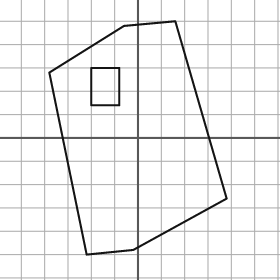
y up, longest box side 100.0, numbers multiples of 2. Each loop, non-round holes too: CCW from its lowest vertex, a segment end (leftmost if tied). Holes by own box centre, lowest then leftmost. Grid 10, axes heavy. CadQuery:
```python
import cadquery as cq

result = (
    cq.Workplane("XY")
    .moveTo(-22.0, -50.0)
    .lineTo(-2.0, -48.0)
    .lineTo(38.0, -26.0)
    .lineTo(16.0, 50.0)
    .lineTo(-6.0, 48.0)
    .lineTo(-38.0, 28.0)
    .close()
    .moveTo(-20.0, 14.0)
    .lineTo(-8.0, 14.0)
    .lineTo(-8.0, 30.0)
    .lineTo(-20.0, 30.0)
    .close()
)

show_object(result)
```